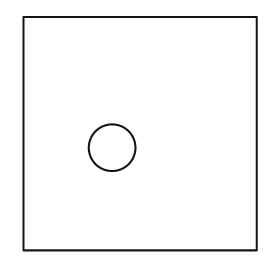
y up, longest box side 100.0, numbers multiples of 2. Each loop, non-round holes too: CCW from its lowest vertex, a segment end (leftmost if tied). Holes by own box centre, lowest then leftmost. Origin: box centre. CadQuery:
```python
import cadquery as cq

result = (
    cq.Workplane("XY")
    .moveTo(-50.0, -50.0)
    .lineTo(50.0, -50.0)
    .lineTo(50.0, 50.0)
    .lineTo(-50.0, 50.0)
    .close()
    .moveTo(-12.0, -6.0)
    .circle(10.0)
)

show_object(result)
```